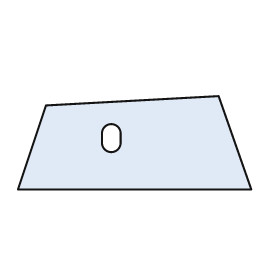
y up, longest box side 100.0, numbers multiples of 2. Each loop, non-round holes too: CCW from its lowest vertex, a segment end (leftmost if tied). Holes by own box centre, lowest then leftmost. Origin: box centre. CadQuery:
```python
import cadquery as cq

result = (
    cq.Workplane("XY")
    .moveTo(-50.0, -20.0)
    .lineTo(50.0, -20.0)
    .lineTo(36.0, 20.0)
    .lineTo(-38.0, 16.0)
    .close()
    .moveTo(-14.0, 0.0)
    .threePointArc((-10.0, -4.0), (-6.0, 0.0))
    .lineTo(-6.0, 4.0)
    .threePointArc((-10.0, 8.0), (-14.0, 4.0))
    .close()
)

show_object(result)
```